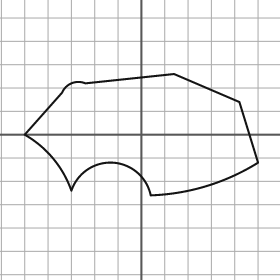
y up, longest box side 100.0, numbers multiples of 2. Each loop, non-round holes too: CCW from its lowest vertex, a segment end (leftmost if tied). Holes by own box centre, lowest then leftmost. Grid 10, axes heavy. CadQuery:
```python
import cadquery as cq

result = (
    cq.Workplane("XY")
    .moveTo(4.0, -26.0)
    .threePointArc((28.0, -22.0), (50.0, -12.0))
    .lineTo(42.0, 14.0)
    .lineTo(14.0, 26.0)
    .lineTo(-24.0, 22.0)
    .threePointArc((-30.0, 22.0), (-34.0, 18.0))
    .lineTo(-50.0, 0.0)
    .threePointArc((-38.0, -10.0), (-30.0, -24.0))
    .threePointArc((-12.0, -12.0), (4.0, -26.0))
    .close()
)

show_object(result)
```